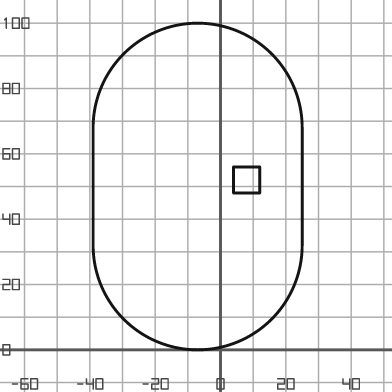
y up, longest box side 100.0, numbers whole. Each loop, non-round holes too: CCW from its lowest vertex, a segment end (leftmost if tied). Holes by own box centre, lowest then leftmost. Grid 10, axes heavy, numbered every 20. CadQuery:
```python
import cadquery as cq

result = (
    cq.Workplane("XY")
    .moveTo(-39.0, 32.0)
    .threePointArc((-7.0, 0.0), (25.0, 32.0))
    .lineTo(25.0, 68.0)
    .threePointArc((-7.0, 100.0), (-39.0, 68.0))
    .close()
    .moveTo(4.0, 48.0)
    .lineTo(12.0, 48.0)
    .lineTo(12.0, 56.0)
    .lineTo(4.0, 56.0)
    .close()
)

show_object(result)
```